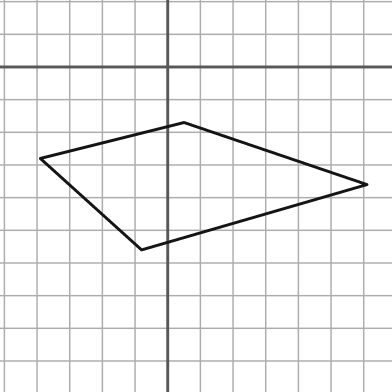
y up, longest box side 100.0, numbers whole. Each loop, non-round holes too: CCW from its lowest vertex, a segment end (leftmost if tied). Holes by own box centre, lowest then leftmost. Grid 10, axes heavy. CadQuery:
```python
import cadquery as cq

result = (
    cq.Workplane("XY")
    .moveTo(-8.0, -56.0)
    .lineTo(61.0, -36.0)
    .lineTo(5.0, -17.0)
    .lineTo(-39.0, -28.0)
    .close()
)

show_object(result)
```